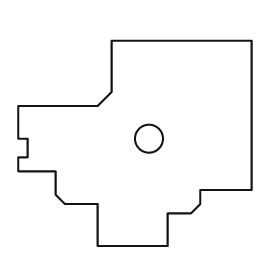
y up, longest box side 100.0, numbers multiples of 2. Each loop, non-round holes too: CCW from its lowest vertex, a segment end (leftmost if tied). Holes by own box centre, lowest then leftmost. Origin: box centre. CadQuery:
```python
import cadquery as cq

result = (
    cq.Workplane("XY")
    .moveTo(-16.0, -44.0)
    .lineTo(14.0, -44.0)
    .lineTo(14.0, -30.0)
    .lineTo(24.0, -30.0)
    .lineTo(28.0, -26.0)
    .lineTo(28.0, -20.0)
    .lineTo(50.0, -20.0)
    .lineTo(50.0, 44.0)
    .lineTo(-10.0, 44.0)
    .lineTo(-10.0, 22.0)
    .lineTo(-16.0, 16.0)
    .lineTo(-50.0, 16.0)
    .lineTo(-50.0, 2.0)
    .lineTo(-46.0, 2.0)
    .lineTo(-46.0, -6.0)
    .lineTo(-50.0, -6.0)
    .lineTo(-50.0, -12.0)
    .lineTo(-34.0, -12.0)
    .lineTo(-34.0, -22.0)
    .lineTo(-30.0, -26.0)
    .lineTo(-16.0, -26.0)
    .close()
    .moveTo(6.0, 2.0)
    .circle(6.0)
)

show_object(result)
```